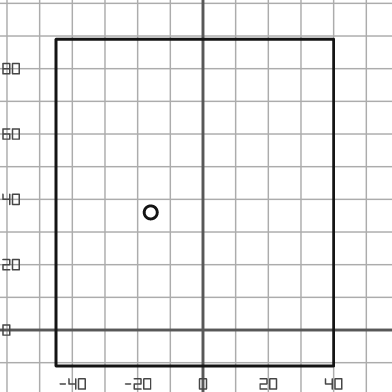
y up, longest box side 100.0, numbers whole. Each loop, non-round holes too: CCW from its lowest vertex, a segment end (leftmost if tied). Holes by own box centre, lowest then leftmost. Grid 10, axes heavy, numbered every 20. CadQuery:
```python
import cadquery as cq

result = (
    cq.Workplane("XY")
    .moveTo(-45.0, -11.0)
    .lineTo(40.0, -11.0)
    .lineTo(40.0, 89.0)
    .lineTo(-45.0, 89.0)
    .close()
    .moveTo(-16.0, 36.0)
    .circle(2.0)
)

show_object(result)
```